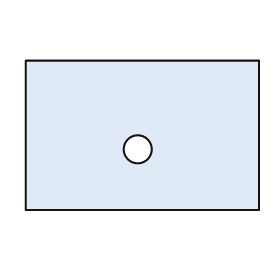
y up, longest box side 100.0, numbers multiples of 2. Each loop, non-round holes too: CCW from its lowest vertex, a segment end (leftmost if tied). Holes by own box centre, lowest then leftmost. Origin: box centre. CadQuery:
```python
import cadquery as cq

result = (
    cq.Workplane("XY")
    .moveTo(-50.0, -32.0)
    .lineTo(50.0, -32.0)
    .lineTo(50.0, 32.0)
    .lineTo(-50.0, 32.0)
    .close()
    .moveTo(-2.0, -6.0)
    .circle(6.0)
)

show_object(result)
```